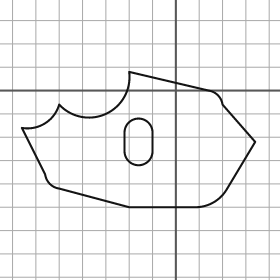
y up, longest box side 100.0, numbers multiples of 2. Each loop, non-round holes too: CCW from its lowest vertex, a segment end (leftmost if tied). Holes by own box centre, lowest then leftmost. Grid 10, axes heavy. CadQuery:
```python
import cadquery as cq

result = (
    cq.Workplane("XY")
    .moveTo(-20.0, -50.0)
    .lineTo(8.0, -50.0)
    .threePointArc((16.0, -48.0), (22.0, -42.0))
    .lineTo(34.0, -22.0)
    .lineTo(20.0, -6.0)
    .threePointArc((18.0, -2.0), (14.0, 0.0))
    .lineTo(-20.0, 8.0)
    .threePointArc((-30.0, -10.0), (-50.0, -6.0))
    .threePointArc((-56.0, -14.0), (-66.0, -16.0))
    .lineTo(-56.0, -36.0)
    .threePointArc((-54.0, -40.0), (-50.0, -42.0))
    .close()
    .moveTo(-22.0, -26.0)
    .threePointArc((-16.0, -32.0), (-10.0, -26.0))
    .lineTo(-10.0, -18.0)
    .threePointArc((-16.0, -12.0), (-22.0, -18.0))
    .close()
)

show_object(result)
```